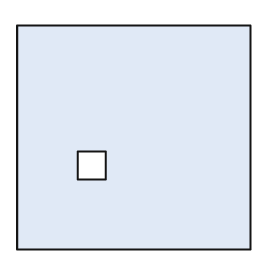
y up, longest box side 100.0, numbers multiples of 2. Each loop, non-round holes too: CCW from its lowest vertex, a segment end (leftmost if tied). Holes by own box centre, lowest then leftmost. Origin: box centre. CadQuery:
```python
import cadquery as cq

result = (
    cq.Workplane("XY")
    .moveTo(-50.0, -48.0)
    .lineTo(50.0, -48.0)
    .lineTo(50.0, 48.0)
    .lineTo(-50.0, 48.0)
    .close()
    .moveTo(-24.0, -18.0)
    .lineTo(-12.0, -18.0)
    .lineTo(-12.0, -6.0)
    .lineTo(-24.0, -6.0)
    .close()
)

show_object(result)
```